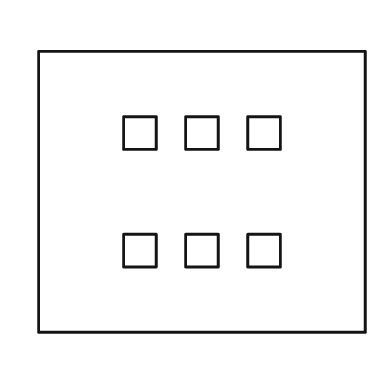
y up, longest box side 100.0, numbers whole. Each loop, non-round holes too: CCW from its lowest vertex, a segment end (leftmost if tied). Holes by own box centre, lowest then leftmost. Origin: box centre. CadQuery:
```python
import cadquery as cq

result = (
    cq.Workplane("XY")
    .moveTo(-50.0, -43.0)
    .lineTo(50.0, -43.0)
    .lineTo(50.0, 43.0)
    .lineTo(-50.0, 43.0)
    .close()
    .moveTo(-24.0, -23.0)
    .lineTo(-14.0, -23.0)
    .lineTo(-14.0, -13.0)
    .lineTo(-24.0, -13.0)
    .close()
    .moveTo(-5.0, -23.0)
    .lineTo(5.0, -23.0)
    .lineTo(5.0, -13.0)
    .lineTo(-5.0, -13.0)
    .close()
    .moveTo(14.0, -23.0)
    .lineTo(24.0, -23.0)
    .lineTo(24.0, -13.0)
    .lineTo(14.0, -13.0)
    .close()
    .moveTo(-24.0, 13.0)
    .lineTo(-14.0, 13.0)
    .lineTo(-14.0, 23.0)
    .lineTo(-24.0, 23.0)
    .close()
    .moveTo(-5.0, 13.0)
    .lineTo(5.0, 13.0)
    .lineTo(5.0, 23.0)
    .lineTo(-5.0, 23.0)
    .close()
    .moveTo(14.0, 13.0)
    .lineTo(24.0, 13.0)
    .lineTo(24.0, 23.0)
    .lineTo(14.0, 23.0)
    .close()
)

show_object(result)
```